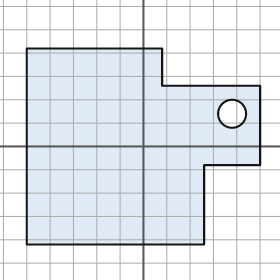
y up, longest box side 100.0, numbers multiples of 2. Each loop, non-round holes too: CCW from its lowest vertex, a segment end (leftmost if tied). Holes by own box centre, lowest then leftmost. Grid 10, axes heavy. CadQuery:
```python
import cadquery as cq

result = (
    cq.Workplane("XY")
    .moveTo(-50.0, -42.0)
    .lineTo(26.0, -42.0)
    .lineTo(26.0, -8.0)
    .lineTo(50.0, -8.0)
    .lineTo(50.0, 26.0)
    .lineTo(8.0, 26.0)
    .lineTo(8.0, 42.0)
    .lineTo(-50.0, 42.0)
    .close()
    .moveTo(38.0, 14.0)
    .circle(6.0)
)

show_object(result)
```